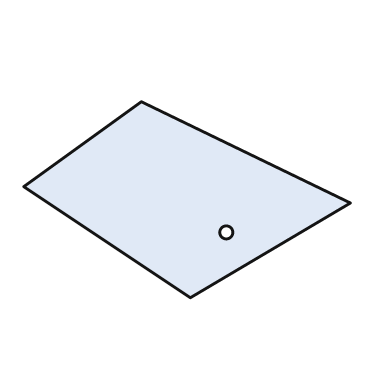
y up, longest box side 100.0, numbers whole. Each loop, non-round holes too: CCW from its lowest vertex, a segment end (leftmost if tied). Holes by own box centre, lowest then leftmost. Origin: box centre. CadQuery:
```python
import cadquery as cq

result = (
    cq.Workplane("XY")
    .moveTo(1.0, -30.0)
    .lineTo(50.0, -1.0)
    .lineTo(-14.0, 30.0)
    .lineTo(-50.0, 4.0)
    .close()
    .moveTo(12.0, -10.0)
    .circle(2.0)
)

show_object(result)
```